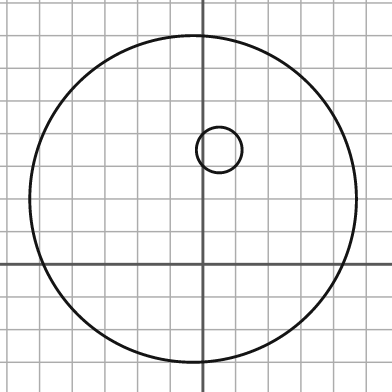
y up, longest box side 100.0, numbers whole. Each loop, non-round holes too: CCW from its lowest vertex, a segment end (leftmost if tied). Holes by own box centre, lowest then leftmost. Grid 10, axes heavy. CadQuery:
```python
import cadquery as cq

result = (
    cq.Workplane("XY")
    .moveTo(-3.0, 20.0)
    .circle(50.0)
    .moveTo(5.0, 35.0)
    .circle(7.0)
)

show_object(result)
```